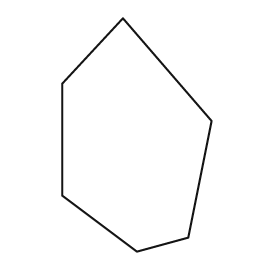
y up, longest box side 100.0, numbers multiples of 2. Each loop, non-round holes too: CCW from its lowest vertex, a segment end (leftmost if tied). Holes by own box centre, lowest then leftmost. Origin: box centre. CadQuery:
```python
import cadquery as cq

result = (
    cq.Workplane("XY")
    .moveTo(0.0, -50.0)
    .lineTo(22.0, -44.0)
    .lineTo(32.0, 6.0)
    .lineTo(-6.0, 50.0)
    .lineTo(-32.0, 22.0)
    .lineTo(-32.0, -26.0)
    .close()
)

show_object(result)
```